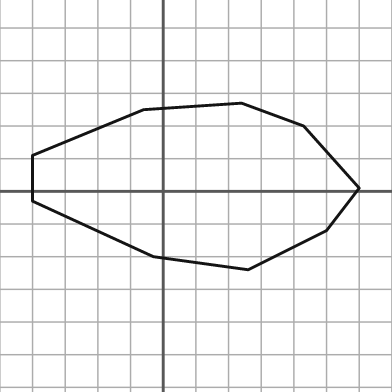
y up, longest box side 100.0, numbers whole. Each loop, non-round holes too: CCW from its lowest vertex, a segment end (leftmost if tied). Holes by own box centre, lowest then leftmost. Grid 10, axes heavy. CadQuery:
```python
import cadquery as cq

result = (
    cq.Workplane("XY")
    .moveTo(26.0, -24.0)
    .lineTo(50.0, -12.0)
    .lineTo(60.0, 1.0)
    .lineTo(43.0, 20.0)
    .lineTo(24.0, 27.0)
    .lineTo(-6.0, 25.0)
    .lineTo(-40.0, 11.0)
    .lineTo(-40.0, -3.0)
    .lineTo(-3.0, -20.0)
    .close()
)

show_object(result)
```